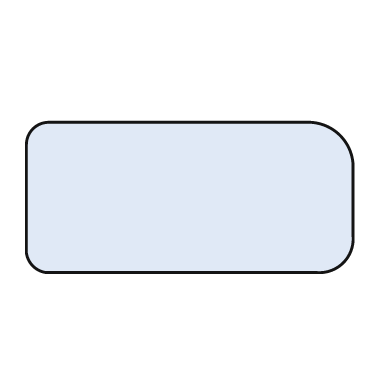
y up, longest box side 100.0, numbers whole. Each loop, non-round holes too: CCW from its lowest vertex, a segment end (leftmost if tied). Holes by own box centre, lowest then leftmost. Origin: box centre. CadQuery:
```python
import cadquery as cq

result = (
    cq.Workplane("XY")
    .moveTo(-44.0, -23.0)
    .lineTo(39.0, -23.0)
    .threePointArc((47.0, -20.0), (50.0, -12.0))
    .lineTo(50.0, 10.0)
    .threePointArc((46.0, 19.0), (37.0, 23.0))
    .lineTo(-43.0, 23.0)
    .threePointArc((-48.0, 21.0), (-50.0, 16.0))
    .lineTo(-50.0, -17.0)
    .threePointArc((-48.0, -21.0), (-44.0, -23.0))
    .close()
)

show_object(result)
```